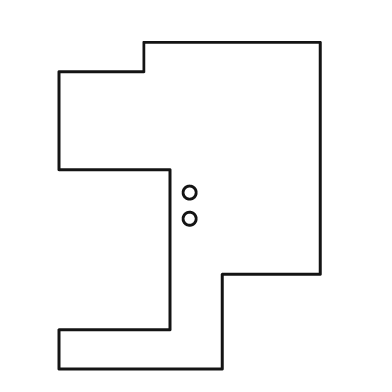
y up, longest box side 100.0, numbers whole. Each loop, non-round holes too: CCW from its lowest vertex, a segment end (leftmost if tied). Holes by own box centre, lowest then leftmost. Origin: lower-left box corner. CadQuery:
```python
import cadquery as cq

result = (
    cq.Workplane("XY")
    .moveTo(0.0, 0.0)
    .lineTo(50.0, 0.0)
    .lineTo(50.0, 29.0)
    .lineTo(80.0, 29.0)
    .lineTo(80.0, 100.0)
    .lineTo(26.0, 100.0)
    .lineTo(26.0, 91.0)
    .lineTo(0.0, 91.0)
    .lineTo(0.0, 61.0)
    .lineTo(34.0, 61.0)
    .lineTo(34.0, 12.0)
    .lineTo(0.0, 12.0)
    .close()
    .moveTo(40.0, 46.0)
    .circle(2.0)
    .moveTo(40.0, 54.0)
    .circle(2.0)
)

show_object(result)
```